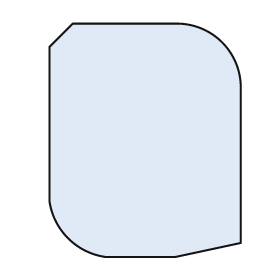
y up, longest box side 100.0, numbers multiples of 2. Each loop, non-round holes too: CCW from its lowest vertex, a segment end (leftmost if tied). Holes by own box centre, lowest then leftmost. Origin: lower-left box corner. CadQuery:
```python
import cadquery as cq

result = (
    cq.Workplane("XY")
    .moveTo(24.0, 0.0)
    .lineTo(54.0, 0.0)
    .lineTo(82.0, 6.0)
    .lineTo(82.0, 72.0)
    .threePointArc((74.0, 92.0), (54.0, 100.0))
    .lineTo(10.0, 100.0)
    .lineTo(0.0, 90.0)
    .lineTo(0.0, 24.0)
    .threePointArc((8.0, 8.0), (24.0, 0.0))
    .close()
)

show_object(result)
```